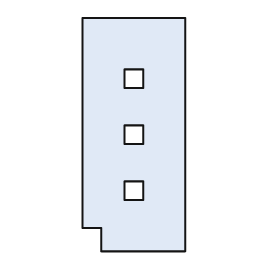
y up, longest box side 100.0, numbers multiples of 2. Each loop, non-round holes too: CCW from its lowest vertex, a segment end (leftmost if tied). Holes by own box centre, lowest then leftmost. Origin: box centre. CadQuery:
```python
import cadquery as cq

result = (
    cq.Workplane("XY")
    .moveTo(-14.0, -50.0)
    .lineTo(22.0, -50.0)
    .lineTo(22.0, 50.0)
    .lineTo(-22.0, 50.0)
    .lineTo(-22.0, -40.0)
    .lineTo(-14.0, -40.0)
    .close()
    .moveTo(-4.0, -28.0)
    .lineTo(4.0, -28.0)
    .lineTo(4.0, -20.0)
    .lineTo(-4.0, -20.0)
    .close()
    .moveTo(-4.0, -4.0)
    .lineTo(4.0, -4.0)
    .lineTo(4.0, 4.0)
    .lineTo(-4.0, 4.0)
    .close()
    .moveTo(-4.0, 20.0)
    .lineTo(4.0, 20.0)
    .lineTo(4.0, 28.0)
    .lineTo(-4.0, 28.0)
    .close()
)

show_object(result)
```